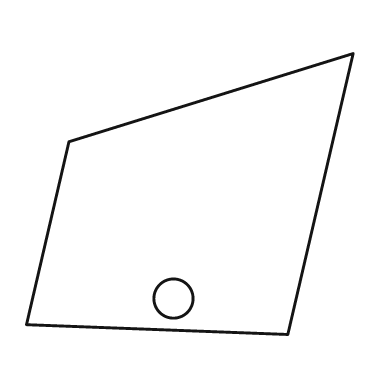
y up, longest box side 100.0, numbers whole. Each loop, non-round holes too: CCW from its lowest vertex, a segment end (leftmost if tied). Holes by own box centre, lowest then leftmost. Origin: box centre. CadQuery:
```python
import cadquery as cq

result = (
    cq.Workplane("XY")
    .moveTo(30.0, -43.0)
    .lineTo(50.0, 43.0)
    .lineTo(-37.0, 16.0)
    .lineTo(-50.0, -40.0)
    .close()
    .moveTo(-5.0, -32.0)
    .circle(6.0)
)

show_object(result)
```